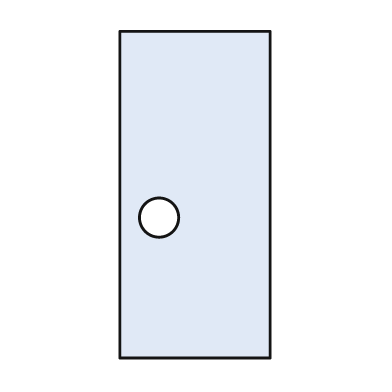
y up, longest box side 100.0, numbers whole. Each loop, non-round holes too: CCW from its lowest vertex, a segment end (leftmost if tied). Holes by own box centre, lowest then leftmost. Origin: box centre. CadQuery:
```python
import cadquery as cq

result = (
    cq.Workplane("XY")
    .moveTo(-23.0, -50.0)
    .lineTo(23.0, -50.0)
    .lineTo(23.0, 50.0)
    .lineTo(-23.0, 50.0)
    .close()
    .moveTo(-11.0, -7.0)
    .circle(6.0)
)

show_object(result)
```